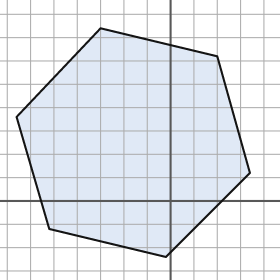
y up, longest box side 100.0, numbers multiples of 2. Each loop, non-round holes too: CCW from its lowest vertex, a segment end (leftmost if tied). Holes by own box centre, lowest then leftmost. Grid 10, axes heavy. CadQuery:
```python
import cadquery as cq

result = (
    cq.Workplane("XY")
    .moveTo(-2.0, -24.0)
    .lineTo(34.0, 12.0)
    .lineTo(20.0, 62.0)
    .lineTo(-30.0, 74.0)
    .lineTo(-66.0, 36.0)
    .lineTo(-52.0, -12.0)
    .close()
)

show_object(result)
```